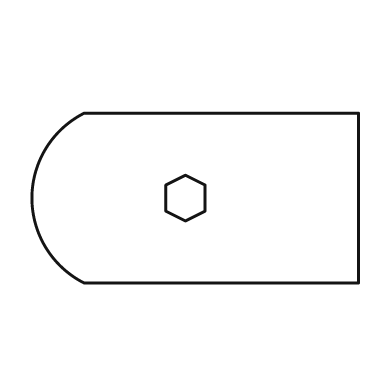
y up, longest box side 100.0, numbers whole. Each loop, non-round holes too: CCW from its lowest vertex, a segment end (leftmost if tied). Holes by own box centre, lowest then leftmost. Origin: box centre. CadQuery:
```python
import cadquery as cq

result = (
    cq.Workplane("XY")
    .moveTo(-34.0, -26.0)
    .lineTo(50.0, -26.0)
    .lineTo(50.0, 26.0)
    .lineTo(-34.0, 26.0)
    .threePointArc((-50.0, 0.0), (-34.0, -26.0))
    .close()
    .moveTo(-3.0, -7.0)
    .lineTo(3.0, -4.0)
    .lineTo(3.0, 4.0)
    .lineTo(-3.0, 7.0)
    .lineTo(-9.0, 4.0)
    .lineTo(-9.0, -4.0)
    .close()
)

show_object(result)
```